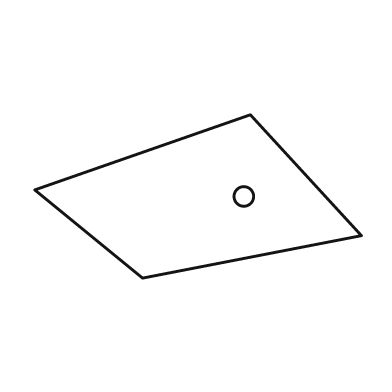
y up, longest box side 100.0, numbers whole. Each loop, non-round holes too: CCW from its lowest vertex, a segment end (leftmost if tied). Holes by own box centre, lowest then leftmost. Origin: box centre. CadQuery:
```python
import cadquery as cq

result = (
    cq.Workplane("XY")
    .moveTo(-17.0, -25.0)
    .lineTo(50.0, -12.0)
    .lineTo(16.0, 25.0)
    .lineTo(-50.0, 2.0)
    .close()
    .moveTo(14.0, 0.0)
    .circle(3.0)
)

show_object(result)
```